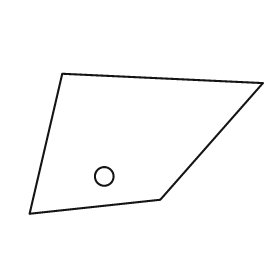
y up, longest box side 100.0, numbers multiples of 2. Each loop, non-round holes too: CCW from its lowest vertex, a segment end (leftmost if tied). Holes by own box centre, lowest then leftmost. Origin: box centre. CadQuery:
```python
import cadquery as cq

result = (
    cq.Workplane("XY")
    .moveTo(-50.0, -30.0)
    .lineTo(6.0, -24.0)
    .lineTo(50.0, 26.0)
    .lineTo(-36.0, 30.0)
    .close()
    .moveTo(-18.0, -14.0)
    .circle(4.0)
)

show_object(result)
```